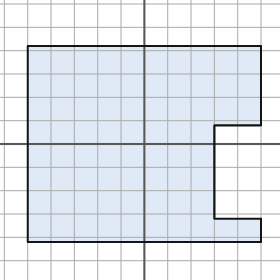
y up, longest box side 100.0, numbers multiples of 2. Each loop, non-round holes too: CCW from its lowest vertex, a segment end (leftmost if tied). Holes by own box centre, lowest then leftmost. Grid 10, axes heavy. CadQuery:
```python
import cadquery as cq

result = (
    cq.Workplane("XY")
    .moveTo(-50.0, -42.0)
    .lineTo(50.0, -42.0)
    .lineTo(50.0, -32.0)
    .lineTo(30.0, -32.0)
    .lineTo(30.0, 8.0)
    .lineTo(50.0, 8.0)
    .lineTo(50.0, 42.0)
    .lineTo(-50.0, 42.0)
    .close()
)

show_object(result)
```